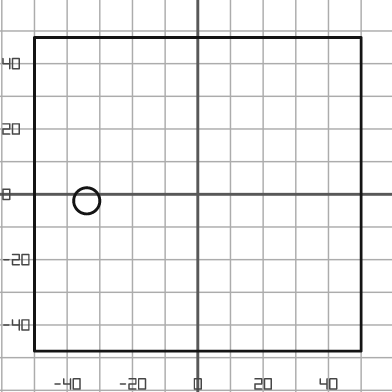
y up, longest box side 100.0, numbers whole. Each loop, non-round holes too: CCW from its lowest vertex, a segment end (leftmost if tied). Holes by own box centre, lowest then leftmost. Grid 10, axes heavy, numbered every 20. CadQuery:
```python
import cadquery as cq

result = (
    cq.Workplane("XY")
    .moveTo(-50.0, -48.0)
    .lineTo(50.0, -48.0)
    .lineTo(50.0, 48.0)
    .lineTo(-50.0, 48.0)
    .close()
    .moveTo(-34.0, -2.0)
    .circle(4.0)
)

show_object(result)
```